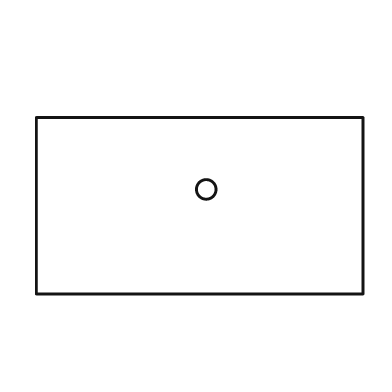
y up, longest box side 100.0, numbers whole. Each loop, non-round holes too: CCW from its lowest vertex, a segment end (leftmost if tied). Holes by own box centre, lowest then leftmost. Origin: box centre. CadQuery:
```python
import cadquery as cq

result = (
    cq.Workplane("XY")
    .moveTo(-50.0, -27.0)
    .lineTo(50.0, -27.0)
    .lineTo(50.0, 27.0)
    .lineTo(-50.0, 27.0)
    .close()
    .moveTo(2.0, 5.0)
    .circle(3.0)
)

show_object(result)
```